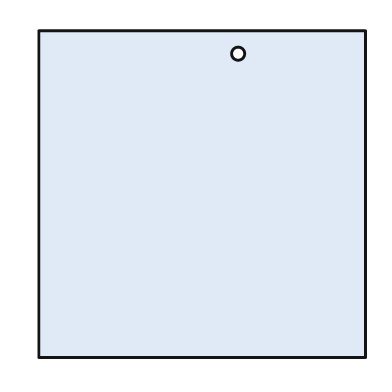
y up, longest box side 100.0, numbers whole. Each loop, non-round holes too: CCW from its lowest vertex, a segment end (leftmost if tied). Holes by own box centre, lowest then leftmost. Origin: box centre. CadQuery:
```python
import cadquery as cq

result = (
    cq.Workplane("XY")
    .moveTo(-50.0, -50.0)
    .lineTo(50.0, -50.0)
    .lineTo(50.0, 50.0)
    .lineTo(-50.0, 50.0)
    .close()
    .moveTo(11.0, 43.0)
    .circle(2.0)
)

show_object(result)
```